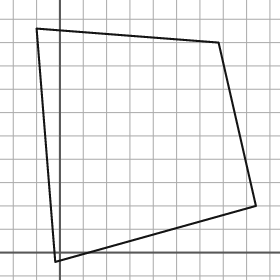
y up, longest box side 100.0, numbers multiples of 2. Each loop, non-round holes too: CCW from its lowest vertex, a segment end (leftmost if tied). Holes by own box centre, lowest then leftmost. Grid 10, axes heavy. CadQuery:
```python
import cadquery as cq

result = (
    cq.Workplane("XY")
    .moveTo(-2.0, -4.0)
    .lineTo(84.0, 20.0)
    .lineTo(68.0, 90.0)
    .lineTo(-10.0, 96.0)
    .close()
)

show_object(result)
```